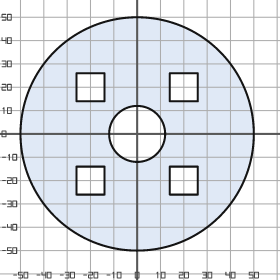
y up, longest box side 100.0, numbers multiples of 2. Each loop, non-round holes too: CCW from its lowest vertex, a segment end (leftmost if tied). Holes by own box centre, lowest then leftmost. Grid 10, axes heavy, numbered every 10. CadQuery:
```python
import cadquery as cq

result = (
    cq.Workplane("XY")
    .moveTo(0.0, 0.0)
    .circle(50.0)
    .moveTo(-26.0, -26.0)
    .lineTo(-14.0, -26.0)
    .lineTo(-14.0, -14.0)
    .lineTo(-26.0, -14.0)
    .close()
    .moveTo(14.0, -26.0)
    .lineTo(26.0, -26.0)
    .lineTo(26.0, -14.0)
    .lineTo(14.0, -14.0)
    .close()
    .moveTo(0.0, 0.0)
    .circle(12.0)
    .moveTo(-26.0, 14.0)
    .lineTo(-14.0, 14.0)
    .lineTo(-14.0, 26.0)
    .lineTo(-26.0, 26.0)
    .close()
    .moveTo(14.0, 14.0)
    .lineTo(26.0, 14.0)
    .lineTo(26.0, 26.0)
    .lineTo(14.0, 26.0)
    .close()
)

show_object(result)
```